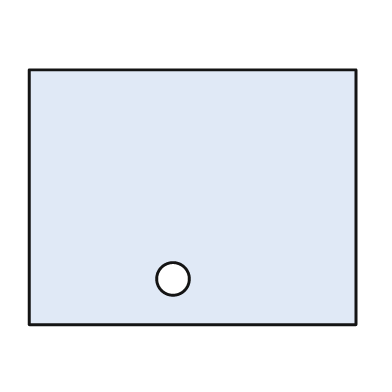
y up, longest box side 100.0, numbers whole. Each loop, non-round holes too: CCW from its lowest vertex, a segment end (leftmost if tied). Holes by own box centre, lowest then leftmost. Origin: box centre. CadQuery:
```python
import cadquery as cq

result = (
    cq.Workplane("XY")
    .moveTo(-50.0, -39.0)
    .lineTo(50.0, -39.0)
    .lineTo(50.0, 39.0)
    .lineTo(-50.0, 39.0)
    .close()
    .moveTo(-6.0, -25.0)
    .circle(5.0)
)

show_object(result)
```